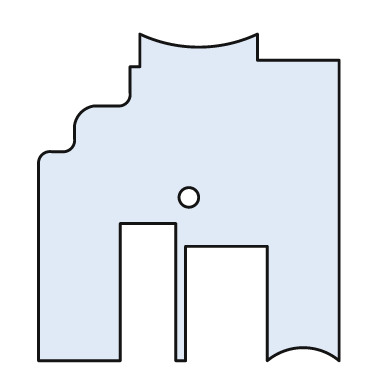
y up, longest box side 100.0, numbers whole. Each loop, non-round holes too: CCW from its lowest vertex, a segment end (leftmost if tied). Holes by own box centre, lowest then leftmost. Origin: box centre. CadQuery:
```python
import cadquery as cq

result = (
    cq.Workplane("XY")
    .moveTo(-46.0, -50.0)
    .lineTo(-21.0, -50.0)
    .lineTo(-21.0, -8.0)
    .lineTo(-4.0, -8.0)
    .lineTo(-4.0, -50.0)
    .lineTo(-1.0, -50.0)
    .lineTo(-1.0, -15.0)
    .lineTo(24.0, -15.0)
    .lineTo(24.0, -50.0)
    .threePointArc((35.0, -46.0), (46.0, -50.0))
    .lineTo(46.0, 42.0)
    .lineTo(21.0, 42.0)
    .lineTo(21.0, 50.0)
    .threePointArc((3.0, 46.0), (-15.0, 50.0))
    .lineTo(-15.0, 40.0)
    .lineTo(-18.0, 40.0)
    .lineTo(-18.0, 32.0)
    .threePointArc((-19.0, 29.0), (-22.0, 28.0))
    .lineTo(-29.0, 28.0)
    .threePointArc((-33.0, 26.0), (-35.0, 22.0))
    .lineTo(-35.0, 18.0)
    .threePointArc((-36.0, 15.0), (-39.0, 14.0))
    .lineTo(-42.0, 14.0)
    .threePointArc((-45.0, 13.0), (-46.0, 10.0))
    .close()
    .moveTo(0.0, 0.0)
    .circle(3.0)
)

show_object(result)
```